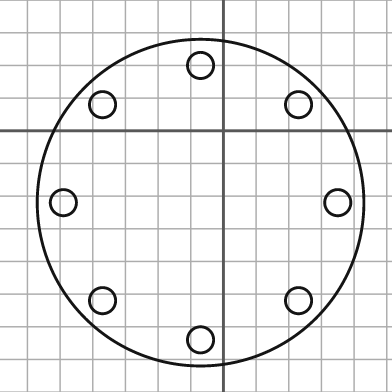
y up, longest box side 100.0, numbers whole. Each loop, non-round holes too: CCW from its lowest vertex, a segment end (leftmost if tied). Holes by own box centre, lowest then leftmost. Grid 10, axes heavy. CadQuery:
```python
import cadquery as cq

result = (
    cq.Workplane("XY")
    .moveTo(-7.0, -22.0)
    .circle(50.0)
    .moveTo(-7.0, -64.0)
    .circle(4.0)
    .moveTo(-37.0, -52.0)
    .circle(4.0)
    .moveTo(23.0, -52.0)
    .circle(4.0)
    .moveTo(-49.0, -22.0)
    .circle(4.0)
    .moveTo(35.0, -22.0)
    .circle(4.0)
    .moveTo(-37.0, 8.0)
    .circle(4.0)
    .moveTo(23.0, 8.0)
    .circle(4.0)
    .moveTo(-7.0, 20.0)
    .circle(4.0)
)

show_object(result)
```